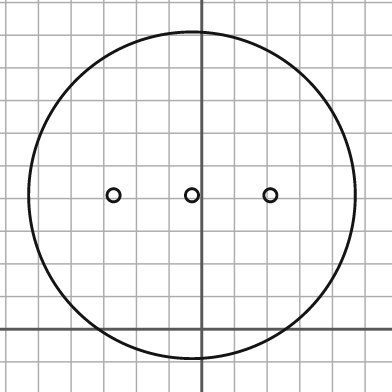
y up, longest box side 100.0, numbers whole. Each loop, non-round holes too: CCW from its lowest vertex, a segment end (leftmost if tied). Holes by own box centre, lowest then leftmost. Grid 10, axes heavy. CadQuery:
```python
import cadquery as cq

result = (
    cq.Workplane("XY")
    .moveTo(-3.0, 41.0)
    .circle(50.0)
    .moveTo(-27.0, 41.0)
    .circle(2.0)
    .moveTo(-3.0, 41.0)
    .circle(2.0)
    .moveTo(21.0, 41.0)
    .circle(2.0)
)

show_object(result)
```